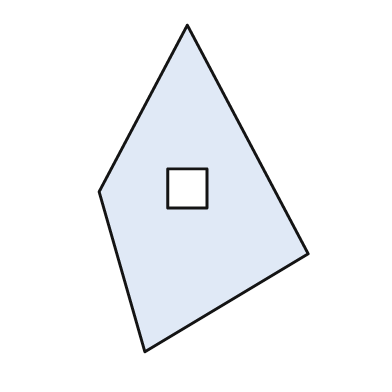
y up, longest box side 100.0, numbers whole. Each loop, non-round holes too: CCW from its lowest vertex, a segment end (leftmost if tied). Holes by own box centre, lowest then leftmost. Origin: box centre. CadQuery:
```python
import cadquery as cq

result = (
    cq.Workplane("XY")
    .moveTo(-18.0, -50.0)
    .lineTo(32.0, -20.0)
    .lineTo(-5.0, 50.0)
    .lineTo(-32.0, -1.0)
    .close()
    .moveTo(-11.0, -6.0)
    .lineTo(1.0, -6.0)
    .lineTo(1.0, 6.0)
    .lineTo(-11.0, 6.0)
    .close()
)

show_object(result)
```